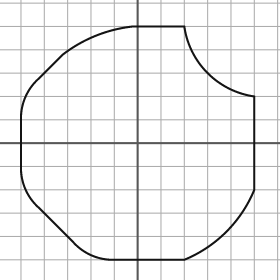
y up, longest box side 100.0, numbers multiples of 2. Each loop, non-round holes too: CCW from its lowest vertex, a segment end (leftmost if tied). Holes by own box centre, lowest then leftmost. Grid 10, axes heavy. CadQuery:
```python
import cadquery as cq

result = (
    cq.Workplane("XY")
    .moveTo(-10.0, -50.0)
    .lineTo(20.0, -50.0)
    .threePointArc((38.0, -38.0), (50.0, -20.0))
    .lineTo(50.0, 20.0)
    .threePointArc((30.0, 30.0), (20.0, 50.0))
    .lineTo(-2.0, 50.0)
    .threePointArc((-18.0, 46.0), (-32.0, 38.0))
    .lineTo(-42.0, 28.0)
    .threePointArc((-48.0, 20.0), (-50.0, 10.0))
    .lineTo(-50.0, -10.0)
    .threePointArc((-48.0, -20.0), (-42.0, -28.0))
    .lineTo(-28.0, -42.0)
    .threePointArc((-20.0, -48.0), (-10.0, -50.0))
    .close()
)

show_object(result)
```